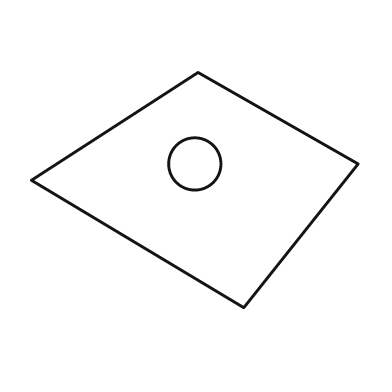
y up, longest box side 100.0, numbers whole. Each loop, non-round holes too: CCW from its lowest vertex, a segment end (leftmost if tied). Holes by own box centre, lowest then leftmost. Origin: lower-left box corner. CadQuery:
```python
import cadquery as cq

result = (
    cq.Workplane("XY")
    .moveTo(65.0, 0.0)
    .lineTo(100.0, 44.0)
    .lineTo(51.0, 72.0)
    .lineTo(0.0, 39.0)
    .close()
    .moveTo(50.0, 44.0)
    .circle(8.0)
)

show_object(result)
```